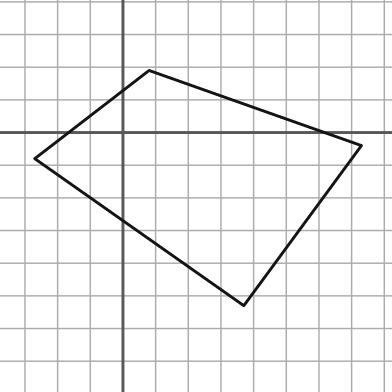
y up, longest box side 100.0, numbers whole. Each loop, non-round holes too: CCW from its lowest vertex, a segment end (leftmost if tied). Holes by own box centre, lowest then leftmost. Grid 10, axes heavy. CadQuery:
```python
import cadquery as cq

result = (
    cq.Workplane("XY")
    .moveTo(37.0, -53.0)
    .lineTo(73.0, -4.0)
    .lineTo(8.0, 19.0)
    .lineTo(-27.0, -8.0)
    .close()
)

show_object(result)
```